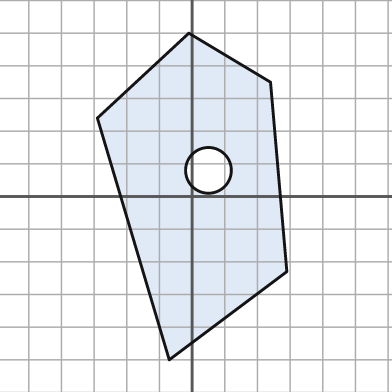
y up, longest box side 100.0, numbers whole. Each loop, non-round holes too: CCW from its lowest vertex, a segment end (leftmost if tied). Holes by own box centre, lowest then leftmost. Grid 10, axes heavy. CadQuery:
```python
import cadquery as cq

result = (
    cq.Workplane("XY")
    .moveTo(-7.0, -50.0)
    .lineTo(29.0, -23.0)
    .lineTo(24.0, 35.0)
    .lineTo(-1.0, 50.0)
    .lineTo(-29.0, 24.0)
    .close()
    .moveTo(5.0, 8.0)
    .circle(7.0)
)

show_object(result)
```